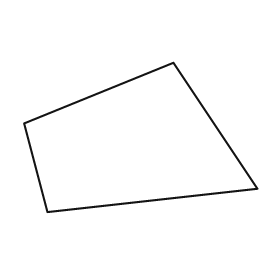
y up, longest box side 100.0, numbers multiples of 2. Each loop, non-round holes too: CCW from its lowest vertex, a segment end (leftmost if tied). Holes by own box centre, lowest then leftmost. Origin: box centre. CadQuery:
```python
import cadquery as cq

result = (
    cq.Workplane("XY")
    .moveTo(-40.0, -32.0)
    .lineTo(50.0, -22.0)
    .lineTo(14.0, 32.0)
    .lineTo(-50.0, 6.0)
    .close()
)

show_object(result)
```